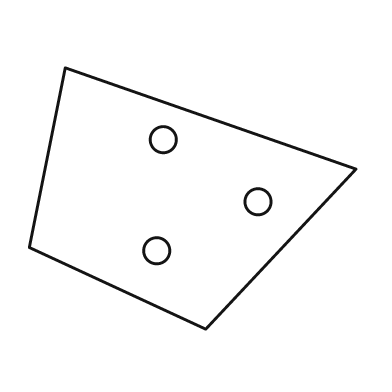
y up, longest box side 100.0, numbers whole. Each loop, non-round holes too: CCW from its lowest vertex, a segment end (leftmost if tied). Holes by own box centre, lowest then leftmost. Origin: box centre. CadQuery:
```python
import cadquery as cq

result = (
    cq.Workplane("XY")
    .moveTo(4.0, -40.0)
    .lineTo(50.0, 9.0)
    .lineTo(-39.0, 40.0)
    .lineTo(-50.0, -15.0)
    .close()
    .moveTo(-11.0, -16.0)
    .circle(4.0)
    .moveTo(20.0, -1.0)
    .circle(4.0)
    .moveTo(-9.0, 18.0)
    .circle(4.0)
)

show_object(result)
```